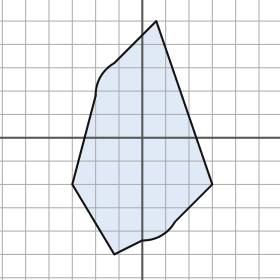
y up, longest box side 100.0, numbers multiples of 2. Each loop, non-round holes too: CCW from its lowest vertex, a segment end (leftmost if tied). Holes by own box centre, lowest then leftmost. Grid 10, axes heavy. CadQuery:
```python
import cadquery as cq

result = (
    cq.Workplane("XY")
    .moveTo(-12.0, -50.0)
    .lineTo(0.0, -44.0)
    .threePointArc((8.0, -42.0), (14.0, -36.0))
    .lineTo(30.0, -20.0)
    .lineTo(6.0, 50.0)
    .lineTo(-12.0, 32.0)
    .threePointArc((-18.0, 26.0), (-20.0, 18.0))
    .lineTo(-30.0, -20.0)
    .close()
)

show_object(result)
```